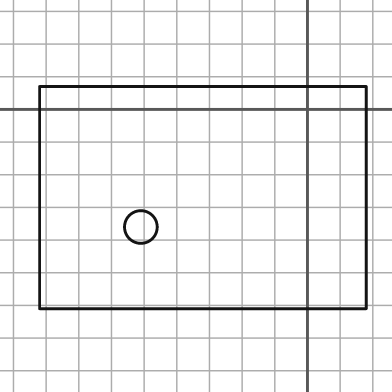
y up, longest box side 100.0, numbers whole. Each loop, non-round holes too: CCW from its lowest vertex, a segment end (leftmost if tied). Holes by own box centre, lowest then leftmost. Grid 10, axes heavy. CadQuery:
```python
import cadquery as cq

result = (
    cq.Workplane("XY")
    .moveTo(-82.0, -61.0)
    .lineTo(18.0, -61.0)
    .lineTo(18.0, 7.0)
    .lineTo(-82.0, 7.0)
    .close()
    .moveTo(-51.0, -36.0)
    .circle(5.0)
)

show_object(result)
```